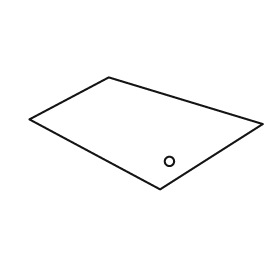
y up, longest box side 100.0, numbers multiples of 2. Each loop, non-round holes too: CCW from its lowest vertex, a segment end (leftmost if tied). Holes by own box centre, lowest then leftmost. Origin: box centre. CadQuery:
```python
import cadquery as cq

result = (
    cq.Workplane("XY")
    .moveTo(6.0, -24.0)
    .lineTo(50.0, 4.0)
    .lineTo(-16.0, 24.0)
    .lineTo(-50.0, 6.0)
    .close()
    .moveTo(10.0, -12.0)
    .circle(2.0)
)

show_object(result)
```